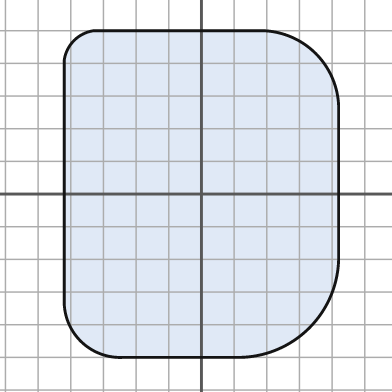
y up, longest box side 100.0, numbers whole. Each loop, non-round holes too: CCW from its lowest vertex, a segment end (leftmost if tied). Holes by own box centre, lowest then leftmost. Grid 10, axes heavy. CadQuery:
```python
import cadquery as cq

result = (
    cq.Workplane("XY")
    .moveTo(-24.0, -50.0)
    .lineTo(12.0, -50.0)
    .threePointArc((33.0, -41.0), (42.0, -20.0))
    .lineTo(42.0, 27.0)
    .threePointArc((35.0, 43.0), (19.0, 50.0))
    .lineTo(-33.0, 50.0)
    .threePointArc((-39.0, 47.0), (-42.0, 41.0))
    .lineTo(-42.0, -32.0)
    .threePointArc((-37.0, -45.0), (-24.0, -50.0))
    .close()
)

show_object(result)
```